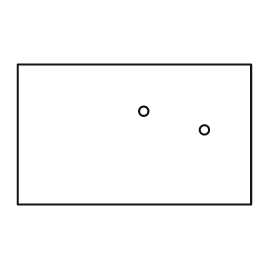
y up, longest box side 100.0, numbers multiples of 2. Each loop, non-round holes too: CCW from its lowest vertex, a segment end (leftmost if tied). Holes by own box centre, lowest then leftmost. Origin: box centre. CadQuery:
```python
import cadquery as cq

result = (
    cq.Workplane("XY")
    .moveTo(-50.0, -30.0)
    .lineTo(50.0, -30.0)
    .lineTo(50.0, 30.0)
    .lineTo(-50.0, 30.0)
    .close()
    .moveTo(30.0, 2.0)
    .circle(2.0)
    .moveTo(4.0, 10.0)
    .circle(2.0)
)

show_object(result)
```